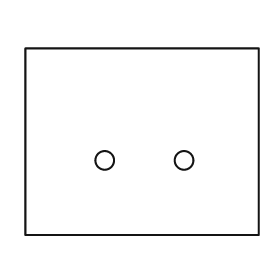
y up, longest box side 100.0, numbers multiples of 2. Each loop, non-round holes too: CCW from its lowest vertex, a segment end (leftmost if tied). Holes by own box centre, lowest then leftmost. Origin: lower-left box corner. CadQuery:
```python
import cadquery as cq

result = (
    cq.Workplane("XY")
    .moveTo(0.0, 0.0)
    .lineTo(100.0, 0.0)
    .lineTo(100.0, 80.0)
    .lineTo(0.0, 80.0)
    .close()
    .moveTo(34.0, 32.0)
    .circle(4.0)
    .moveTo(68.0, 32.0)
    .circle(4.0)
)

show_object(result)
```